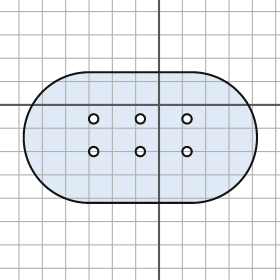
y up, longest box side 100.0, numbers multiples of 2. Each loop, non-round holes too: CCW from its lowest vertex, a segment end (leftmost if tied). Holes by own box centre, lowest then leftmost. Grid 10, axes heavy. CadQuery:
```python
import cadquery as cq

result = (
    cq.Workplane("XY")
    .moveTo(-30.0, -42.0)
    .lineTo(14.0, -42.0)
    .threePointArc((42.0, -14.0), (14.0, 14.0))
    .lineTo(-30.0, 14.0)
    .threePointArc((-58.0, -14.0), (-30.0, -42.0))
    .close()
    .moveTo(-28.0, -20.0)
    .circle(2.0)
    .moveTo(-8.0, -20.0)
    .circle(2.0)
    .moveTo(12.0, -20.0)
    .circle(2.0)
    .moveTo(-28.0, -6.0)
    .circle(2.0)
    .moveTo(-8.0, -6.0)
    .circle(2.0)
    .moveTo(12.0, -6.0)
    .circle(2.0)
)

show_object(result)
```